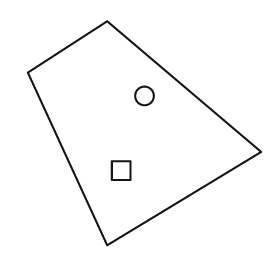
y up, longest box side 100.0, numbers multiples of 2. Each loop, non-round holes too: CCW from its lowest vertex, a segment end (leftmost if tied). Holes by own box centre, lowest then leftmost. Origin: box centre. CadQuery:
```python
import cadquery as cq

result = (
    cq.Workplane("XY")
    .moveTo(-16.0, -48.0)
    .lineTo(50.0, -8.0)
    .lineTo(-16.0, 48.0)
    .lineTo(-50.0, 26.0)
    .close()
    .moveTo(-14.0, -20.0)
    .lineTo(-6.0, -20.0)
    .lineTo(-6.0, -12.0)
    .lineTo(-14.0, -12.0)
    .close()
    .moveTo(0.0, 16.0)
    .circle(4.0)
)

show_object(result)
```